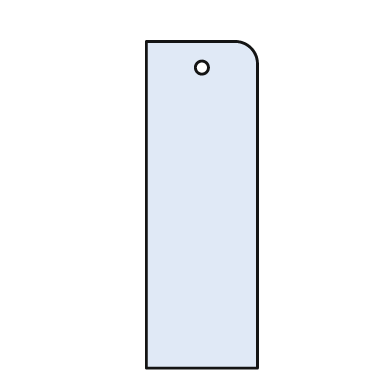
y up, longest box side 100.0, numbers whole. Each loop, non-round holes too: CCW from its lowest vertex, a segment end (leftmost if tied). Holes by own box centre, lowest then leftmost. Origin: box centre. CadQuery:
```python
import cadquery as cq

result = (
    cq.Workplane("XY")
    .moveTo(-17.0, -50.0)
    .lineTo(17.0, -50.0)
    .lineTo(17.0, 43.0)
    .threePointArc((15.0, 48.0), (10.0, 50.0))
    .lineTo(-17.0, 50.0)
    .close()
    .moveTo(0.0, 42.0)
    .circle(2.0)
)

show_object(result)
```